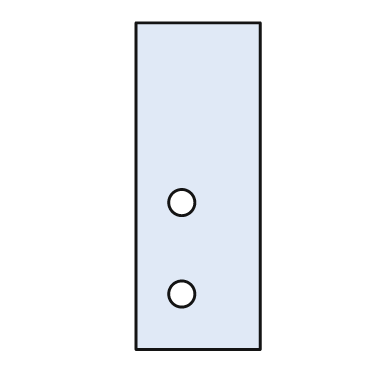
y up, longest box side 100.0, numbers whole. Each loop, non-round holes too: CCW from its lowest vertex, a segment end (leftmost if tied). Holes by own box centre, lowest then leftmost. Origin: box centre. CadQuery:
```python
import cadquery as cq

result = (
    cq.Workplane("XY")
    .moveTo(-19.0, -50.0)
    .lineTo(19.0, -50.0)
    .lineTo(19.0, 50.0)
    .lineTo(-19.0, 50.0)
    .close()
    .moveTo(-5.0, -33.0)
    .circle(4.0)
    .moveTo(-5.0, -5.0)
    .circle(4.0)
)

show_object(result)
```